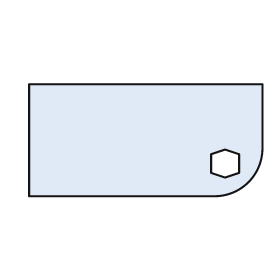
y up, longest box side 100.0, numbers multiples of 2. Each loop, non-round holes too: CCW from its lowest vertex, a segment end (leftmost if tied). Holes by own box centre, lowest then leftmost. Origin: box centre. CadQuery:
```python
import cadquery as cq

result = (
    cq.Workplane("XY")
    .moveTo(-50.0, -24.0)
    .lineTo(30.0, -24.0)
    .threePointArc((44.0, -18.0), (50.0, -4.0))
    .lineTo(50.0, 24.0)
    .lineTo(-50.0, 24.0)
    .close()
    .moveTo(34.0, -16.0)
    .lineTo(40.0, -14.0)
    .lineTo(40.0, -6.0)
    .lineTo(34.0, -4.0)
    .lineTo(28.0, -6.0)
    .lineTo(28.0, -14.0)
    .close()
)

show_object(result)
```